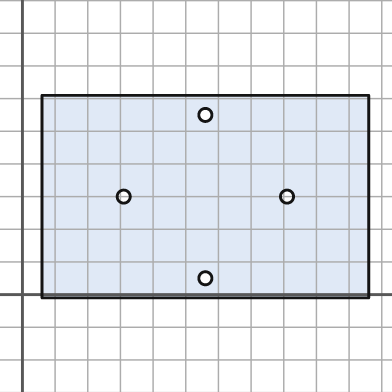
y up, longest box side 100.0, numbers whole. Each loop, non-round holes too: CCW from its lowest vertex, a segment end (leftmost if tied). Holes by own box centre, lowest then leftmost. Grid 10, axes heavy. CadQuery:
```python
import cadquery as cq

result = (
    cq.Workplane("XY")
    .moveTo(6.0, -1.0)
    .lineTo(106.0, -1.0)
    .lineTo(106.0, 61.0)
    .lineTo(6.0, 61.0)
    .close()
    .moveTo(56.0, 5.0)
    .circle(2.0)
    .moveTo(31.0, 30.0)
    .circle(2.0)
    .moveTo(81.0, 30.0)
    .circle(2.0)
    .moveTo(56.0, 55.0)
    .circle(2.0)
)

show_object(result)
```